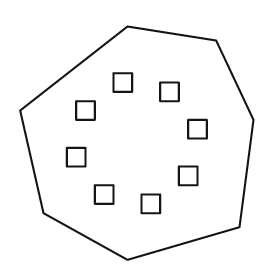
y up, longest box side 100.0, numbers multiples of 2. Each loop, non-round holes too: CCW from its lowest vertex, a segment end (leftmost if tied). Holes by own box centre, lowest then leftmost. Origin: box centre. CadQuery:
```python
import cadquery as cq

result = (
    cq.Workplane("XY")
    .moveTo(-4.0, -50.0)
    .lineTo(44.0, -36.0)
    .lineTo(50.0, 10.0)
    .lineTo(34.0, 44.0)
    .lineTo(-4.0, 50.0)
    .lineTo(-50.0, 14.0)
    .lineTo(-40.0, -30.0)
    .close()
    .moveTo(2.0, -30.0)
    .lineTo(10.0, -30.0)
    .lineTo(10.0, -22.0)
    .lineTo(2.0, -22.0)
    .close()
    .moveTo(-18.0, -26.0)
    .lineTo(-10.0, -26.0)
    .lineTo(-10.0, -18.0)
    .lineTo(-18.0, -18.0)
    .close()
    .moveTo(18.0, -18.0)
    .lineTo(26.0, -18.0)
    .lineTo(26.0, -10.0)
    .lineTo(18.0, -10.0)
    .close()
    .moveTo(-30.0, -10.0)
    .lineTo(-22.0, -10.0)
    .lineTo(-22.0, -2.0)
    .lineTo(-30.0, -2.0)
    .close()
    .moveTo(22.0, 2.0)
    .lineTo(30.0, 2.0)
    .lineTo(30.0, 10.0)
    .lineTo(22.0, 10.0)
    .close()
    .moveTo(-26.0, 10.0)
    .lineTo(-18.0, 10.0)
    .lineTo(-18.0, 18.0)
    .lineTo(-26.0, 18.0)
    .close()
    .moveTo(10.0, 18.0)
    .lineTo(18.0, 18.0)
    .lineTo(18.0, 26.0)
    .lineTo(10.0, 26.0)
    .close()
    .moveTo(-10.0, 22.0)
    .lineTo(-2.0, 22.0)
    .lineTo(-2.0, 30.0)
    .lineTo(-10.0, 30.0)
    .close()
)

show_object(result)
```